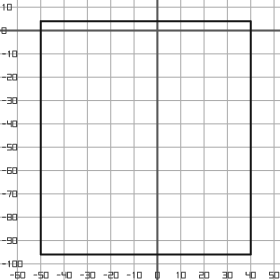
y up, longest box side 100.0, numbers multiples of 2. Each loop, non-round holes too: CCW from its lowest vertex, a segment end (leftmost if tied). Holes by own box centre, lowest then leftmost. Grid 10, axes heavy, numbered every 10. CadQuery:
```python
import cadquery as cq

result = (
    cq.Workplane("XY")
    .moveTo(-50.0, -96.0)
    .lineTo(40.0, -96.0)
    .lineTo(40.0, 4.0)
    .lineTo(-50.0, 4.0)
    .close()
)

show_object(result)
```